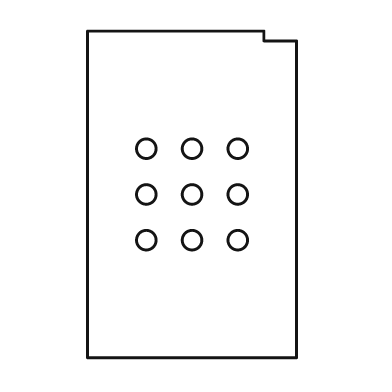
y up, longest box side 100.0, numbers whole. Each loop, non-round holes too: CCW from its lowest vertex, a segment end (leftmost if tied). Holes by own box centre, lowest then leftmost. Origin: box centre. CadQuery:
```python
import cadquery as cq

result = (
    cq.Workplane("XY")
    .moveTo(-32.0, -50.0)
    .lineTo(32.0, -50.0)
    .lineTo(32.0, 47.0)
    .lineTo(22.0, 47.0)
    .lineTo(22.0, 50.0)
    .lineTo(-32.0, 50.0)
    .close()
    .moveTo(-14.0, -14.0)
    .circle(3.0)
    .moveTo(0.0, -14.0)
    .circle(3.0)
    .moveTo(14.0, -14.0)
    .circle(3.0)
    .moveTo(-14.0, 0.0)
    .circle(3.0)
    .moveTo(0.0, 0.0)
    .circle(3.0)
    .moveTo(14.0, 0.0)
    .circle(3.0)
    .moveTo(-14.0, 14.0)
    .circle(3.0)
    .moveTo(0.0, 14.0)
    .circle(3.0)
    .moveTo(14.0, 14.0)
    .circle(3.0)
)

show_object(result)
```